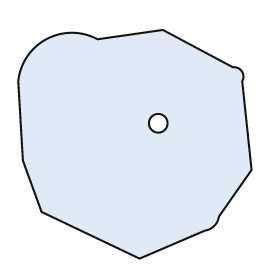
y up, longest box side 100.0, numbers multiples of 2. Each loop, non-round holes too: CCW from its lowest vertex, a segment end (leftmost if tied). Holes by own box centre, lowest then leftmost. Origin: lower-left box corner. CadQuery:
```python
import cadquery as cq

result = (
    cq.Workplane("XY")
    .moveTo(52.0, 0.0)
    .lineTo(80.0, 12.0)
    .threePointArc((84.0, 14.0), (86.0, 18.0))
    .lineTo(100.0, 38.0)
    .lineTo(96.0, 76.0)
    .threePointArc((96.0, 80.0), (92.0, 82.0))
    .lineTo(62.0, 98.0)
    .lineTo(34.0, 94.0)
    .threePointArc((12.0, 94.0), (0.0, 76.0))
    .lineTo(2.0, 42.0)
    .lineTo(10.0, 20.0)
    .close()
    .moveTo(60.0, 58.0)
    .circle(4.0)
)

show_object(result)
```